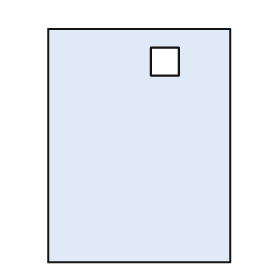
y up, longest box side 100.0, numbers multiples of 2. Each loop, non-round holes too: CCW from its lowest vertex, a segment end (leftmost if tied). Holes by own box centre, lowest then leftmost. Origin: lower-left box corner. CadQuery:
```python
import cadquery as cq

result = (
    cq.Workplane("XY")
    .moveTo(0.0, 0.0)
    .lineTo(78.0, 0.0)
    .lineTo(78.0, 100.0)
    .lineTo(0.0, 100.0)
    .close()
    .moveTo(44.0, 80.0)
    .lineTo(56.0, 80.0)
    .lineTo(56.0, 92.0)
    .lineTo(44.0, 92.0)
    .close()
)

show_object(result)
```